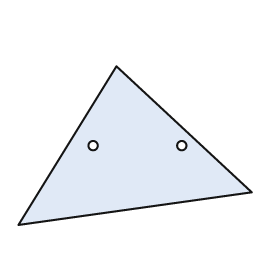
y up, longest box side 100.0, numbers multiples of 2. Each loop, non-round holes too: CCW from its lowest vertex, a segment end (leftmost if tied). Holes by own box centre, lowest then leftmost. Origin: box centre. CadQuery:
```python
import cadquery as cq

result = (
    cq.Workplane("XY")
    .moveTo(-50.0, -34.0)
    .lineTo(50.0, -20.0)
    .lineTo(-8.0, 34.0)
    .close()
    .moveTo(-18.0, 0.0)
    .circle(2.0)
    .moveTo(20.0, 0.0)
    .circle(2.0)
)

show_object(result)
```